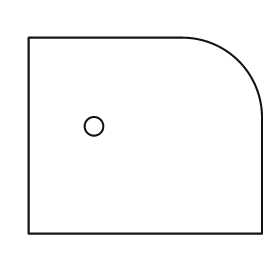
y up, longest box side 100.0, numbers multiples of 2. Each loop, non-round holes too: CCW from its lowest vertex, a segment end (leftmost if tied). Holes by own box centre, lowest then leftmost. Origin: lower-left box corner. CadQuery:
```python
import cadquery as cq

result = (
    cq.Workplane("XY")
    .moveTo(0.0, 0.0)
    .lineTo(100.0, 0.0)
    .lineTo(100.0, 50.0)
    .threePointArc((90.0, 74.0), (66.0, 84.0))
    .lineTo(0.0, 84.0)
    .close()
    .moveTo(28.0, 46.0)
    .circle(4.0)
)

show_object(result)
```